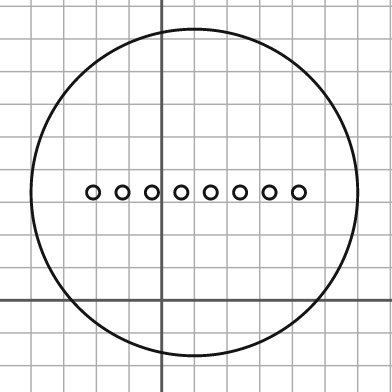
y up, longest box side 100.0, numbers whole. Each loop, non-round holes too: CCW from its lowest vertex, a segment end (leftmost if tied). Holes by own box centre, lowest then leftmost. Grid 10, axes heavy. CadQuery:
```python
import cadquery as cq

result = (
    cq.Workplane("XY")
    .moveTo(10.0, 33.0)
    .circle(50.0)
    .moveTo(-21.0, 33.0)
    .circle(2.0)
    .moveTo(-12.0, 33.0)
    .circle(2.0)
    .moveTo(-3.0, 33.0)
    .circle(2.0)
    .moveTo(6.0, 33.0)
    .circle(2.0)
    .moveTo(15.0, 33.0)
    .circle(2.0)
    .moveTo(24.0, 33.0)
    .circle(2.0)
    .moveTo(33.0, 33.0)
    .circle(2.0)
    .moveTo(42.0, 33.0)
    .circle(2.0)
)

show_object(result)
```